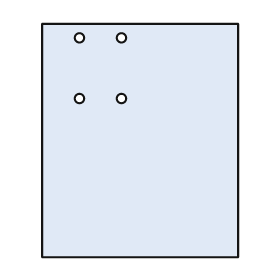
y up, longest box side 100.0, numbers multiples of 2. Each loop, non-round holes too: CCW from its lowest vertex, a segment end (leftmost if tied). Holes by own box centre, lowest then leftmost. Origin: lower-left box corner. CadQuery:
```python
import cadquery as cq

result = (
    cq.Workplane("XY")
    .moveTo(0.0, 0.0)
    .lineTo(84.0, 0.0)
    .lineTo(84.0, 100.0)
    .lineTo(0.0, 100.0)
    .close()
    .moveTo(16.0, 68.0)
    .circle(2.0)
    .moveTo(34.0, 68.0)
    .circle(2.0)
    .moveTo(16.0, 94.0)
    .circle(2.0)
    .moveTo(34.0, 94.0)
    .circle(2.0)
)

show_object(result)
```